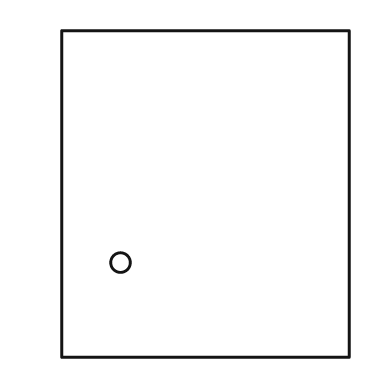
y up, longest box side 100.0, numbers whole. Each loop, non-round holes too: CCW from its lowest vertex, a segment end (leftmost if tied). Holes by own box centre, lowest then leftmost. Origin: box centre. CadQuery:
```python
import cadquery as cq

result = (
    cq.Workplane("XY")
    .moveTo(-44.0, -50.0)
    .lineTo(44.0, -50.0)
    .lineTo(44.0, 50.0)
    .lineTo(-44.0, 50.0)
    .close()
    .moveTo(-26.0, -21.0)
    .circle(3.0)
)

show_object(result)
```